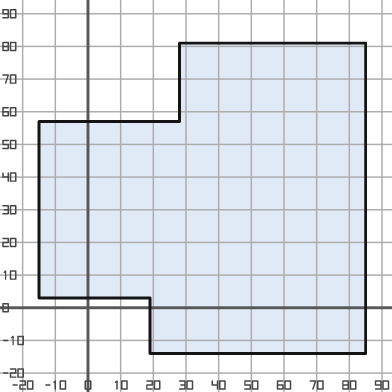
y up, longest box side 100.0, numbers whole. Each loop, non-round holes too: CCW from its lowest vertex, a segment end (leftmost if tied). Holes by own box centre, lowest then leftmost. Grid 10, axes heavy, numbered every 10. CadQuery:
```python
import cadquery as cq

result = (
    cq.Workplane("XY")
    .moveTo(19.0, -14.0)
    .lineTo(85.0, -14.0)
    .lineTo(85.0, 81.0)
    .lineTo(28.0, 81.0)
    .lineTo(28.0, 57.0)
    .lineTo(-15.0, 57.0)
    .lineTo(-15.0, 3.0)
    .lineTo(19.0, 3.0)
    .close()
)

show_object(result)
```